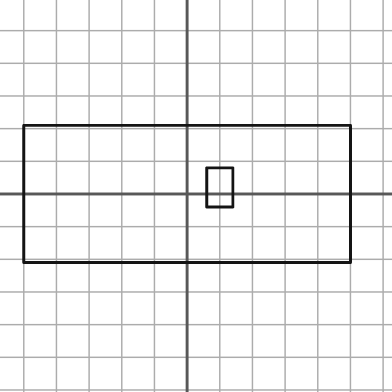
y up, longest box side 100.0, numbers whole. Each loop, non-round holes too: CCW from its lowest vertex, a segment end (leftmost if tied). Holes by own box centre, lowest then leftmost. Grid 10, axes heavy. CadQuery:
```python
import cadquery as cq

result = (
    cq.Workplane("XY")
    .moveTo(-50.0, -21.0)
    .lineTo(50.0, -21.0)
    .lineTo(50.0, 21.0)
    .lineTo(-50.0, 21.0)
    .close()
    .moveTo(6.0, -4.0)
    .lineTo(14.0, -4.0)
    .lineTo(14.0, 8.0)
    .lineTo(6.0, 8.0)
    .close()
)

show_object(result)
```